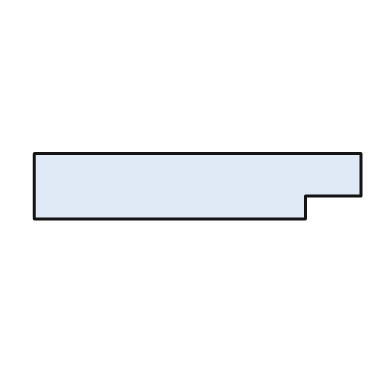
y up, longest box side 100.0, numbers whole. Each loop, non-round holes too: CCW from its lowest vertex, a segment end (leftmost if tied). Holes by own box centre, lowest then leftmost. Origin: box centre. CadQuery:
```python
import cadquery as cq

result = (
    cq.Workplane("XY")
    .moveTo(-50.0, -10.0)
    .lineTo(33.0, -10.0)
    .lineTo(33.0, -3.0)
    .lineTo(50.0, -3.0)
    .lineTo(50.0, 10.0)
    .lineTo(-50.0, 10.0)
    .close()
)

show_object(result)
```